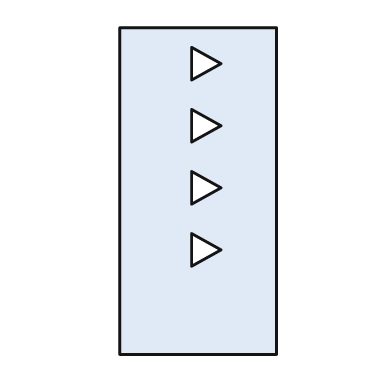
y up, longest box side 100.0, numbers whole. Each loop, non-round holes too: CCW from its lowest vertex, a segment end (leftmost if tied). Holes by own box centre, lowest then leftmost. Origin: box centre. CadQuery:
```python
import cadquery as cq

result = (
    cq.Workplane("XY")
    .moveTo(-24.0, -50.0)
    .lineTo(24.0, -50.0)
    .lineTo(24.0, 50.0)
    .lineTo(-24.0, 50.0)
    .close()
    .moveTo(-2.0, -23.0)
    .lineTo(7.0, -18.0)
    .lineTo(-2.0, -13.0)
    .close()
    .moveTo(-2.0, -4.0)
    .lineTo(7.0, 1.0)
    .lineTo(-2.0, 6.0)
    .close()
    .moveTo(-2.0, 15.0)
    .lineTo(7.0, 20.0)
    .lineTo(-2.0, 25.0)
    .close()
    .moveTo(-2.0, 34.0)
    .lineTo(7.0, 39.0)
    .lineTo(-2.0, 44.0)
    .close()
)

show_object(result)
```